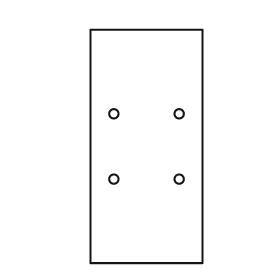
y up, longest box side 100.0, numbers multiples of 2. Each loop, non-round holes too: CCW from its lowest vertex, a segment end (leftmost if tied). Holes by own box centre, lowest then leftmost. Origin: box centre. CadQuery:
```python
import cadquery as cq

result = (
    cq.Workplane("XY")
    .moveTo(-24.0, -50.0)
    .lineTo(24.0, -50.0)
    .lineTo(24.0, 50.0)
    .lineTo(-24.0, 50.0)
    .close()
    .moveTo(-14.0, -14.0)
    .circle(2.0)
    .moveTo(14.0, -14.0)
    .circle(2.0)
    .moveTo(-14.0, 14.0)
    .circle(2.0)
    .moveTo(14.0, 14.0)
    .circle(2.0)
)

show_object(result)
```